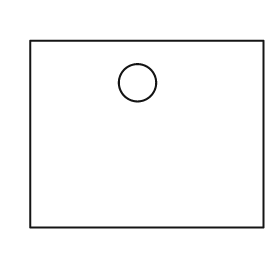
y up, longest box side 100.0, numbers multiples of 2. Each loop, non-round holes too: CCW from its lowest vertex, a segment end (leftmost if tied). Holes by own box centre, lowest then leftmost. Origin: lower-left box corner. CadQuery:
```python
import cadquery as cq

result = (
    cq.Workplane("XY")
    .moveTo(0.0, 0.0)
    .lineTo(100.0, 0.0)
    .lineTo(100.0, 80.0)
    .lineTo(0.0, 80.0)
    .close()
    .moveTo(46.0, 62.0)
    .circle(8.0)
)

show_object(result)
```